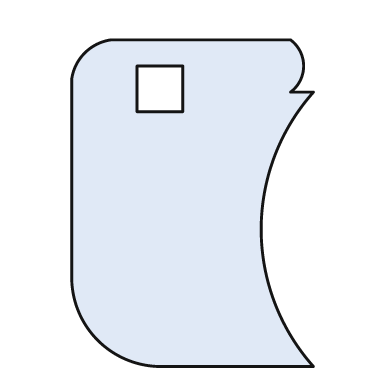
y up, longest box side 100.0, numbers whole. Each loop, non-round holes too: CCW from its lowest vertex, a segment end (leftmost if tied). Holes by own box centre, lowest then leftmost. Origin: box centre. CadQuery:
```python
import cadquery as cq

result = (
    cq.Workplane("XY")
    .moveTo(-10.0, -50.0)
    .lineTo(37.0, -50.0)
    .threePointArc((21.0, -8.0), (37.0, 34.0))
    .lineTo(30.0, 34.0)
    .threePointArc((34.0, 42.0), (30.0, 50.0))
    .lineTo(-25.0, 50.0)
    .threePointArc((-33.0, 46.0), (-37.0, 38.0))
    .lineTo(-37.0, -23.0)
    .threePointArc((-29.0, -42.0), (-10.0, -50.0))
    .close()
    .moveTo(-17.0, 28.0)
    .lineTo(-3.0, 28.0)
    .lineTo(-3.0, 42.0)
    .lineTo(-17.0, 42.0)
    .close()
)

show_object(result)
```